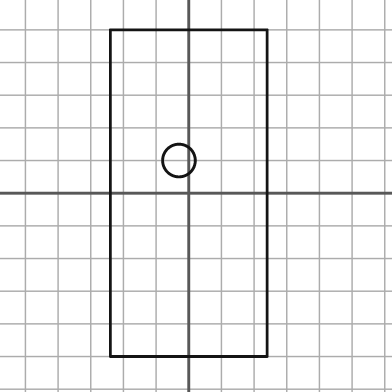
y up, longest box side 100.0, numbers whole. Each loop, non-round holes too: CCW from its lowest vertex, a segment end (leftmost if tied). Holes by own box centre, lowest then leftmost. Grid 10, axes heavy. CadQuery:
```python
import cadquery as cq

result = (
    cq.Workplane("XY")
    .moveTo(-24.0, -50.0)
    .lineTo(24.0, -50.0)
    .lineTo(24.0, 50.0)
    .lineTo(-24.0, 50.0)
    .close()
    .moveTo(-3.0, 10.0)
    .circle(5.0)
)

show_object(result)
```